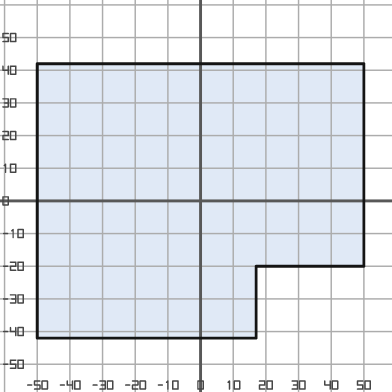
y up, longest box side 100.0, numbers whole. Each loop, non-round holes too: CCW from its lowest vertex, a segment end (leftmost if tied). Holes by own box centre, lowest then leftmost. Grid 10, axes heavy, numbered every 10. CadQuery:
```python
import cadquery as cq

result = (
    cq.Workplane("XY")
    .moveTo(-50.0, -42.0)
    .lineTo(17.0, -42.0)
    .lineTo(17.0, -20.0)
    .lineTo(50.0, -20.0)
    .lineTo(50.0, 42.0)
    .lineTo(-50.0, 42.0)
    .close()
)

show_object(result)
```